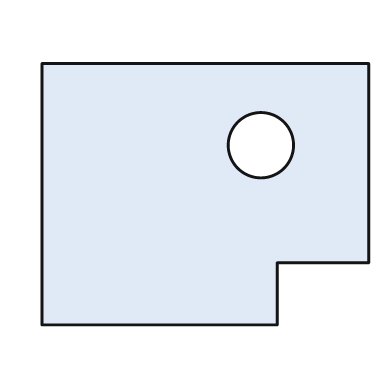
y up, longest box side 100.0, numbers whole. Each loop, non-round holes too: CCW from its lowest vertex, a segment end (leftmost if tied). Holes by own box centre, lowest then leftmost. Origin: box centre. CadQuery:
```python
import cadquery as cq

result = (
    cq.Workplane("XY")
    .moveTo(-50.0, -40.0)
    .lineTo(22.0, -40.0)
    .lineTo(22.0, -21.0)
    .lineTo(50.0, -21.0)
    .lineTo(50.0, 40.0)
    .lineTo(-50.0, 40.0)
    .close()
    .moveTo(17.0, 15.0)
    .circle(10.0)
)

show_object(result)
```